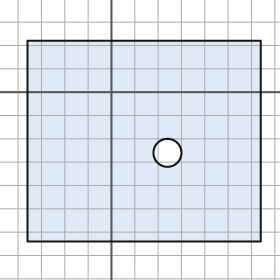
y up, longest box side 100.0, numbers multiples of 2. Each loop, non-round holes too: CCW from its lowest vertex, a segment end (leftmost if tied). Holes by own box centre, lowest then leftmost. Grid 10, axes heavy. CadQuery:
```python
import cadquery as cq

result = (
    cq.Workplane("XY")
    .moveTo(-36.0, -64.0)
    .lineTo(64.0, -64.0)
    .lineTo(64.0, 22.0)
    .lineTo(-36.0, 22.0)
    .close()
    .moveTo(24.0, -26.0)
    .circle(6.0)
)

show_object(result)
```